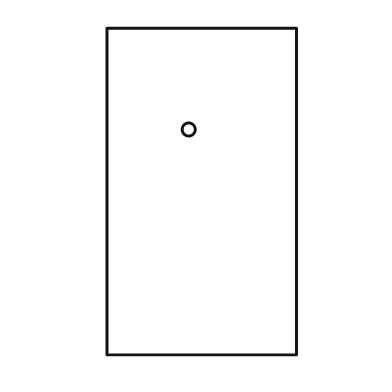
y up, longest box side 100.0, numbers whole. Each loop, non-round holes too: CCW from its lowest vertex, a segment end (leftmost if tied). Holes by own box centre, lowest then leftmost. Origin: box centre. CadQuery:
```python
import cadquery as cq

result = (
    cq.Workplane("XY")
    .moveTo(-29.0, -50.0)
    .lineTo(29.0, -50.0)
    .lineTo(29.0, 50.0)
    .lineTo(-29.0, 50.0)
    .close()
    .moveTo(-4.0, 19.0)
    .circle(2.0)
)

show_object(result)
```